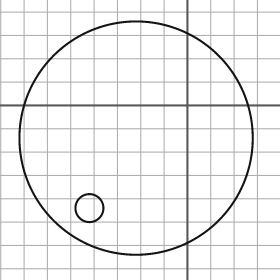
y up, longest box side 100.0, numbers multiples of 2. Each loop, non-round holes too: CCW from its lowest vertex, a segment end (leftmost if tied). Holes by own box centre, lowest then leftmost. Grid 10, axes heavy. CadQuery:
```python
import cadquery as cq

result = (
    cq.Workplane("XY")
    .moveTo(-22.0, -14.0)
    .circle(50.0)
    .moveTo(-42.0, -44.0)
    .circle(6.0)
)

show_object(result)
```